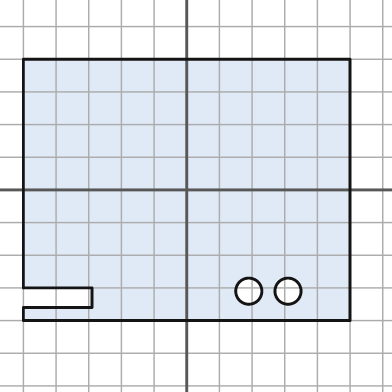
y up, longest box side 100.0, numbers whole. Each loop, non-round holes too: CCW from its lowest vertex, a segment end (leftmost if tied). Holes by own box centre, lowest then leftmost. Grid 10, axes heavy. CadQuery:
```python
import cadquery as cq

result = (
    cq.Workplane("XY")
    .moveTo(-50.0, -40.0)
    .lineTo(50.0, -40.0)
    .lineTo(50.0, 40.0)
    .lineTo(-50.0, 40.0)
    .lineTo(-50.0, -30.0)
    .lineTo(-29.0, -30.0)
    .lineTo(-29.0, -36.0)
    .lineTo(-50.0, -36.0)
    .close()
    .moveTo(19.0, -31.0)
    .circle(4.0)
    .moveTo(31.0, -31.0)
    .circle(4.0)
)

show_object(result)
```